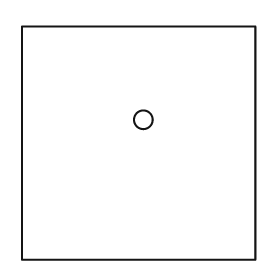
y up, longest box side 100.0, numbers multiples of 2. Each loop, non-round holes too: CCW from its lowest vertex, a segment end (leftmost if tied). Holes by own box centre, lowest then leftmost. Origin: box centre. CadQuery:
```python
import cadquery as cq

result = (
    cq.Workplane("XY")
    .moveTo(-50.0, -50.0)
    .lineTo(50.0, -50.0)
    .lineTo(50.0, 50.0)
    .lineTo(-50.0, 50.0)
    .close()
    .moveTo(2.0, 10.0)
    .circle(4.0)
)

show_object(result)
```